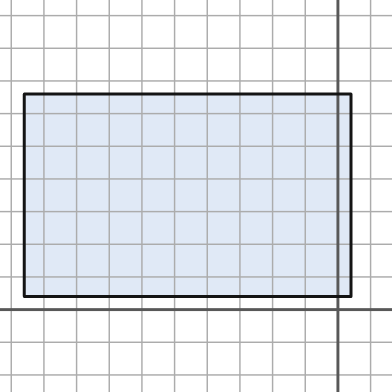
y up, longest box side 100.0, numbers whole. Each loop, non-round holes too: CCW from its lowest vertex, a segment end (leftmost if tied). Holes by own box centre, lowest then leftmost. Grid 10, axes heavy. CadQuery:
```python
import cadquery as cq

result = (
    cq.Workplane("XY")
    .moveTo(-96.0, 4.0)
    .lineTo(4.0, 4.0)
    .lineTo(4.0, 66.0)
    .lineTo(-96.0, 66.0)
    .close()
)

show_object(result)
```